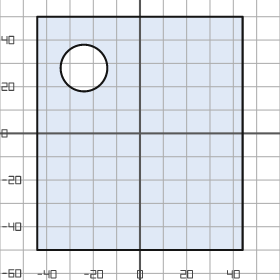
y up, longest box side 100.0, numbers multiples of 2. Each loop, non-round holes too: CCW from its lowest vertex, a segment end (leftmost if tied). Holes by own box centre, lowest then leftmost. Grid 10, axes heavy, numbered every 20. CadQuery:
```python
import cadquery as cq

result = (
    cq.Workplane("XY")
    .moveTo(-44.0, -50.0)
    .lineTo(44.0, -50.0)
    .lineTo(44.0, 50.0)
    .lineTo(-44.0, 50.0)
    .close()
    .moveTo(-24.0, 28.0)
    .circle(10.0)
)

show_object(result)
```